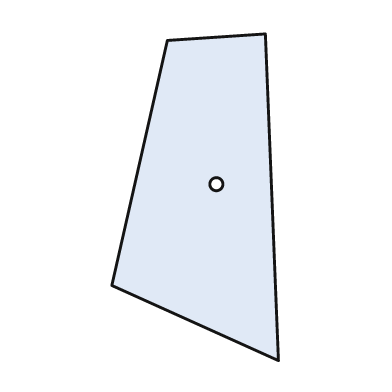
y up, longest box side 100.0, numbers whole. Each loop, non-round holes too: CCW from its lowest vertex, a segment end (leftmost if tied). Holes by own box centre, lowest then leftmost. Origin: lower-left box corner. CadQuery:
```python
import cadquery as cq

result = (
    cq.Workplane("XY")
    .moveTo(51.0, 0.0)
    .lineTo(47.0, 100.0)
    .lineTo(17.0, 98.0)
    .lineTo(0.0, 23.0)
    .close()
    .moveTo(32.0, 54.0)
    .circle(2.0)
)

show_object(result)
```